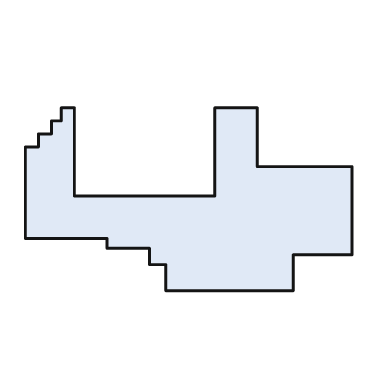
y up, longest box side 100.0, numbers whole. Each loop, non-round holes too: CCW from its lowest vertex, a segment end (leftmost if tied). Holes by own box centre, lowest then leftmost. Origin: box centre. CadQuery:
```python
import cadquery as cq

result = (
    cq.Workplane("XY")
    .moveTo(-7.0, -28.0)
    .lineTo(32.0, -28.0)
    .lineTo(32.0, -17.0)
    .lineTo(50.0, -17.0)
    .lineTo(50.0, 10.0)
    .lineTo(21.0, 10.0)
    .lineTo(21.0, 28.0)
    .lineTo(8.0, 28.0)
    .lineTo(8.0, 1.0)
    .lineTo(-35.0, 1.0)
    .lineTo(-35.0, 28.0)
    .lineTo(-39.0, 28.0)
    .lineTo(-39.0, 24.0)
    .lineTo(-42.0, 24.0)
    .lineTo(-42.0, 20.0)
    .lineTo(-46.0, 20.0)
    .lineTo(-46.0, 16.0)
    .lineTo(-50.0, 16.0)
    .lineTo(-50.0, -12.0)
    .lineTo(-25.0, -12.0)
    .lineTo(-25.0, -15.0)
    .lineTo(-12.0, -15.0)
    .lineTo(-12.0, -20.0)
    .lineTo(-7.0, -20.0)
    .close()
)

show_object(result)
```